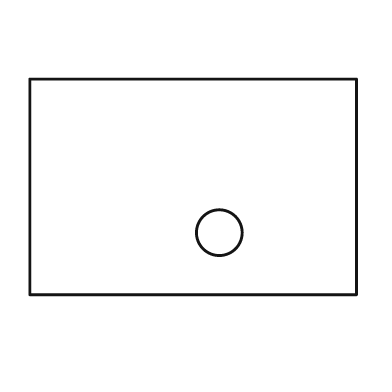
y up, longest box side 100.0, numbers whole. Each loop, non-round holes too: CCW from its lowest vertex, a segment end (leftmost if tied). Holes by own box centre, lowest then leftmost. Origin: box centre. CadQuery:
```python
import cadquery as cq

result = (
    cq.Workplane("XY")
    .moveTo(-50.0, -33.0)
    .lineTo(50.0, -33.0)
    .lineTo(50.0, 33.0)
    .lineTo(-50.0, 33.0)
    .close()
    .moveTo(8.0, -14.0)
    .circle(7.0)
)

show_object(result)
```